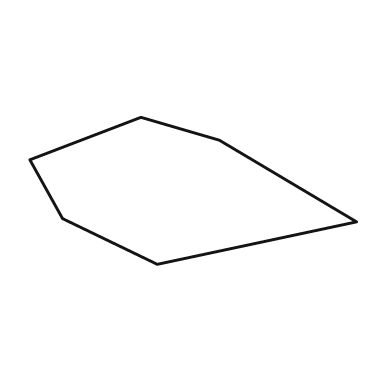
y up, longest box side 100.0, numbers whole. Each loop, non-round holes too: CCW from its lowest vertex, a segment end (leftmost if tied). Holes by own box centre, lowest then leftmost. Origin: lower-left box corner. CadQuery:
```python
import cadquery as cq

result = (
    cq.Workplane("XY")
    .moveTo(39.0, 0.0)
    .lineTo(100.0, 13.0)
    .lineTo(58.0, 38.0)
    .lineTo(34.0, 45.0)
    .lineTo(0.0, 32.0)
    .lineTo(10.0, 14.0)
    .close()
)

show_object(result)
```